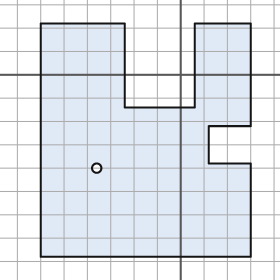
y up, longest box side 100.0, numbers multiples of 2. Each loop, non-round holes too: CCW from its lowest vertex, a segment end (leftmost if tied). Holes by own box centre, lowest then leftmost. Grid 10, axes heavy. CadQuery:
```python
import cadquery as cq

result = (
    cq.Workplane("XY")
    .moveTo(-60.0, -78.0)
    .lineTo(30.0, -78.0)
    .lineTo(30.0, -38.0)
    .lineTo(12.0, -38.0)
    .lineTo(12.0, -22.0)
    .lineTo(30.0, -22.0)
    .lineTo(30.0, 22.0)
    .lineTo(6.0, 22.0)
    .lineTo(6.0, -14.0)
    .lineTo(-24.0, -14.0)
    .lineTo(-24.0, 22.0)
    .lineTo(-60.0, 22.0)
    .close()
    .moveTo(-36.0, -40.0)
    .circle(2.0)
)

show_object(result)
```